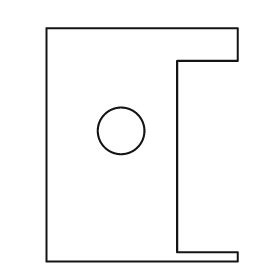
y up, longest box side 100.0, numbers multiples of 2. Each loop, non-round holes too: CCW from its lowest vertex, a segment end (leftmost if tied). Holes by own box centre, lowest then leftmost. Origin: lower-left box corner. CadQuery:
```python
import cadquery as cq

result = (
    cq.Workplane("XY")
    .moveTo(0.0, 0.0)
    .lineTo(82.0, 0.0)
    .lineTo(82.0, 4.0)
    .lineTo(56.0, 4.0)
    .lineTo(56.0, 86.0)
    .lineTo(82.0, 86.0)
    .lineTo(82.0, 100.0)
    .lineTo(0.0, 100.0)
    .close()
    .moveTo(32.0, 56.0)
    .circle(10.0)
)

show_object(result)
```